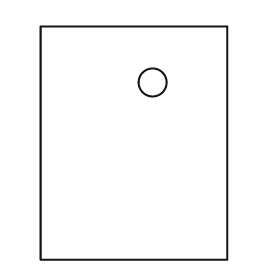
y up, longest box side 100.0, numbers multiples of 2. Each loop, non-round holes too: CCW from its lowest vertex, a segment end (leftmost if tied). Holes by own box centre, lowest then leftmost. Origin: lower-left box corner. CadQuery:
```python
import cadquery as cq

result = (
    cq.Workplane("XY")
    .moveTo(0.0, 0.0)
    .lineTo(80.0, 0.0)
    .lineTo(80.0, 100.0)
    .lineTo(0.0, 100.0)
    .close()
    .moveTo(48.0, 76.0)
    .circle(6.0)
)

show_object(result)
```